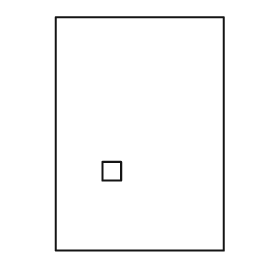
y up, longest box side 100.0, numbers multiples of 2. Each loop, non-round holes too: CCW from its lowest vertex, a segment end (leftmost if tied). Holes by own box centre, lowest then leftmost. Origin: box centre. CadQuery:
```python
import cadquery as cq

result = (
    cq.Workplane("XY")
    .moveTo(-36.0, -50.0)
    .lineTo(36.0, -50.0)
    .lineTo(36.0, 50.0)
    .lineTo(-36.0, 50.0)
    .close()
    .moveTo(-16.0, -20.0)
    .lineTo(-8.0, -20.0)
    .lineTo(-8.0, -12.0)
    .lineTo(-16.0, -12.0)
    .close()
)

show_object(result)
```